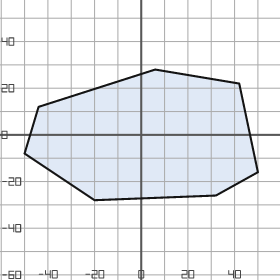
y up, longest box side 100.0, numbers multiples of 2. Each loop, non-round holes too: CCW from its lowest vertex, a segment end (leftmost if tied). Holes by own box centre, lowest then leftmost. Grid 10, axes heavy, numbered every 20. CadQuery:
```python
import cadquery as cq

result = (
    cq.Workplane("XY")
    .moveTo(-20.0, -28.0)
    .lineTo(32.0, -26.0)
    .lineTo(50.0, -16.0)
    .lineTo(42.0, 22.0)
    .lineTo(6.0, 28.0)
    .lineTo(-44.0, 12.0)
    .lineTo(-50.0, -8.0)
    .close()
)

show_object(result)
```